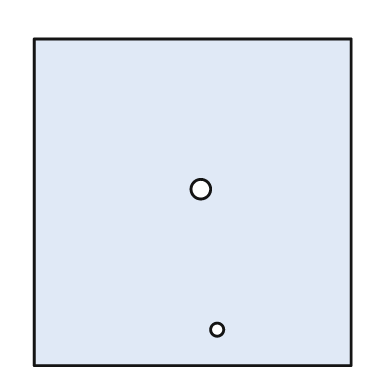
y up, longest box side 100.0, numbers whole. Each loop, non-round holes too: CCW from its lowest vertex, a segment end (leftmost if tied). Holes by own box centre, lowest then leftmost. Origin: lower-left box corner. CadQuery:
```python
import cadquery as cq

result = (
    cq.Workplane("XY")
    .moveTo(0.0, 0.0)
    .lineTo(97.0, 0.0)
    .lineTo(97.0, 100.0)
    .lineTo(0.0, 100.0)
    .close()
    .moveTo(56.0, 11.0)
    .circle(2.0)
    .moveTo(51.0, 54.0)
    .circle(3.0)
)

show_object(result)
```